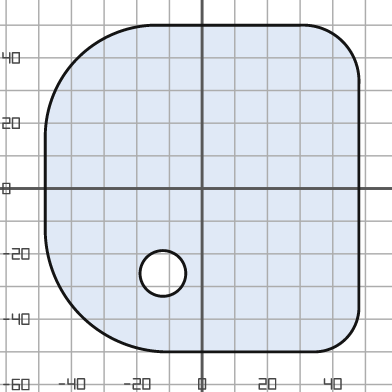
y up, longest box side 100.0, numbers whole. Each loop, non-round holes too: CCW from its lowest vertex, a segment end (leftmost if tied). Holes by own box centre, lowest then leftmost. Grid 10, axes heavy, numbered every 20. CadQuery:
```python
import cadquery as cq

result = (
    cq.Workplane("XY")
    .moveTo(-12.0, -50.0)
    .lineTo(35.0, -50.0)
    .threePointArc((44.0, -46.0), (48.0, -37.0))
    .lineTo(48.0, 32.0)
    .threePointArc((43.0, 45.0), (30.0, 50.0))
    .lineTo(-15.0, 50.0)
    .threePointArc((-38.0, 40.0), (-48.0, 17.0))
    .lineTo(-48.0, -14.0)
    .threePointArc((-37.0, -39.0), (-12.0, -50.0))
    .close()
    .moveTo(-12.0, -26.0)
    .circle(7.0)
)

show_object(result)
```